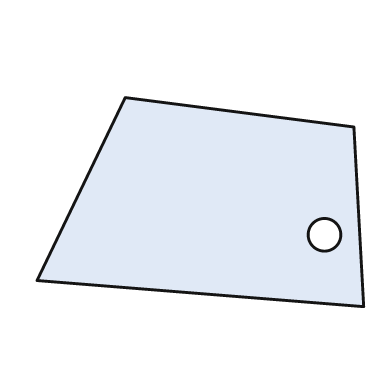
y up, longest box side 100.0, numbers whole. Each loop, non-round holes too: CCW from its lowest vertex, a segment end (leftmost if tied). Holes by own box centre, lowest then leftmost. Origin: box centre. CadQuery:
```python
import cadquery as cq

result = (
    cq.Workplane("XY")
    .moveTo(50.0, -32.0)
    .lineTo(47.0, 23.0)
    .lineTo(-23.0, 32.0)
    .lineTo(-50.0, -24.0)
    .close()
    .moveTo(38.0, -10.0)
    .circle(5.0)
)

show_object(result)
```